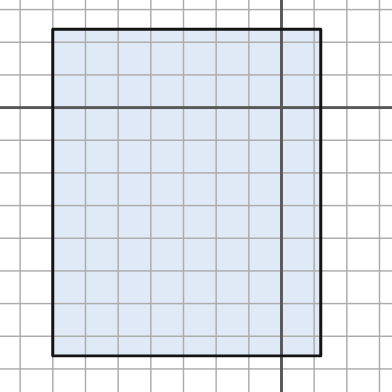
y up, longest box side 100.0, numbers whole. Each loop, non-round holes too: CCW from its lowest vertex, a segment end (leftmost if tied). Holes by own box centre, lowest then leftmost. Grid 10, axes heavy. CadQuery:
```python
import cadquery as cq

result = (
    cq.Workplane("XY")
    .moveTo(-70.0, -76.0)
    .lineTo(12.0, -76.0)
    .lineTo(12.0, 24.0)
    .lineTo(-70.0, 24.0)
    .close()
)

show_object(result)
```